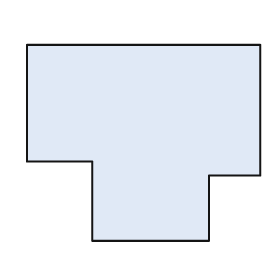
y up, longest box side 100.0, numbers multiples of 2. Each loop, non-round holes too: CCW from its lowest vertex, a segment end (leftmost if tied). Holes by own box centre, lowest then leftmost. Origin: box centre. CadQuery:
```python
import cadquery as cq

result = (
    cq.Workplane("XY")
    .moveTo(-22.0, -42.0)
    .lineTo(28.0, -42.0)
    .lineTo(28.0, -14.0)
    .lineTo(50.0, -14.0)
    .lineTo(50.0, 42.0)
    .lineTo(-50.0, 42.0)
    .lineTo(-50.0, -8.0)
    .lineTo(-22.0, -8.0)
    .close()
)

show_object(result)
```